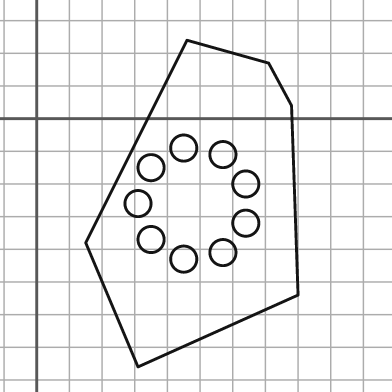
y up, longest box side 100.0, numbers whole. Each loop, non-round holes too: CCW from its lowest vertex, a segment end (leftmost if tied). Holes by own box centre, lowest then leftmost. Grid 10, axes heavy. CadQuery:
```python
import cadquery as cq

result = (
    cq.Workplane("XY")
    .moveTo(31.0, -76.0)
    .lineTo(80.0, -54.0)
    .lineTo(78.0, 4.0)
    .lineTo(71.0, 17.0)
    .lineTo(46.0, 24.0)
    .lineTo(15.0, -38.0)
    .close()
    .moveTo(45.0, -43.0)
    .circle(4.0)
    .moveTo(57.0, -41.0)
    .circle(4.0)
    .moveTo(35.0, -37.0)
    .circle(4.0)
    .moveTo(64.0, -32.0)
    .circle(4.0)
    .moveTo(31.0, -26.0)
    .circle(4.0)
    .moveTo(64.0, -20.0)
    .circle(4.0)
    .moveTo(35.0, -15.0)
    .circle(4.0)
    .moveTo(57.0, -11.0)
    .circle(4.0)
    .moveTo(45.0, -9.0)
    .circle(4.0)
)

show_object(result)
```